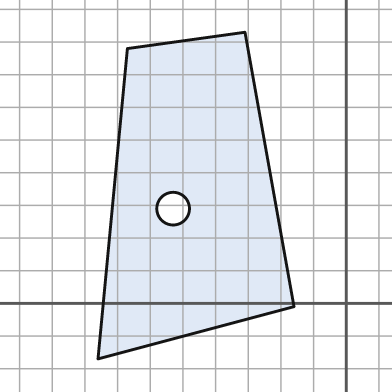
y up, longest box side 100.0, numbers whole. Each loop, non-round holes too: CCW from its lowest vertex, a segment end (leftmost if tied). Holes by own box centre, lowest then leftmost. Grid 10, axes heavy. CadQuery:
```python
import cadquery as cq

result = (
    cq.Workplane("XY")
    .moveTo(-76.0, -17.0)
    .lineTo(-16.0, -1.0)
    .lineTo(-31.0, 83.0)
    .lineTo(-67.0, 78.0)
    .close()
    .moveTo(-53.0, 29.0)
    .circle(5.0)
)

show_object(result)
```